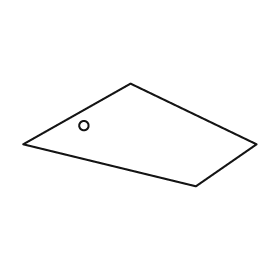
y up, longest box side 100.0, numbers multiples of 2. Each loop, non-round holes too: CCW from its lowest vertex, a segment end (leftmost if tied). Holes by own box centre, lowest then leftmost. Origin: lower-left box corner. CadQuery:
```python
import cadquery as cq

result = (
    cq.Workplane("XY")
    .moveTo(74.0, 0.0)
    .lineTo(100.0, 18.0)
    .lineTo(46.0, 44.0)
    .lineTo(0.0, 18.0)
    .close()
    .moveTo(26.0, 26.0)
    .circle(2.0)
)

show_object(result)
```